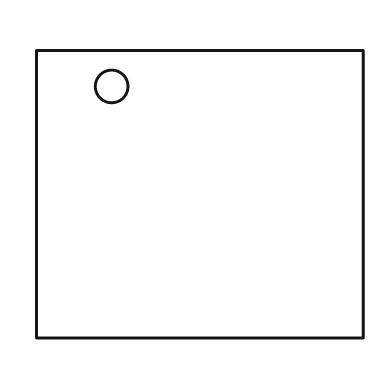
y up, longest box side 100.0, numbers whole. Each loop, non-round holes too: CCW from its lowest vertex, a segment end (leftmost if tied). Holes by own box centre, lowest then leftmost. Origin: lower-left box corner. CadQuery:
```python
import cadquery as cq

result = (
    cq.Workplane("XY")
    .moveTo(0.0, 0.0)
    .lineTo(100.0, 0.0)
    .lineTo(100.0, 88.0)
    .lineTo(0.0, 88.0)
    .close()
    .moveTo(23.0, 77.0)
    .circle(5.0)
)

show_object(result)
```